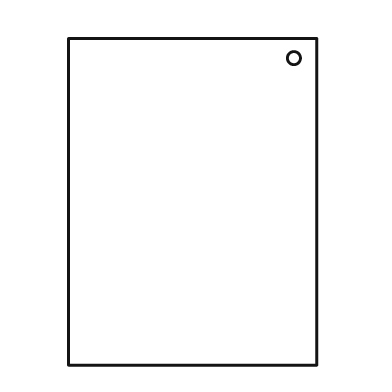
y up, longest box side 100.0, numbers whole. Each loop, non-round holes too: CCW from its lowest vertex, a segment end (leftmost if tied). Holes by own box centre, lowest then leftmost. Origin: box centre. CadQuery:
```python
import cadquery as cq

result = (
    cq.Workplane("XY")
    .moveTo(-38.0, -50.0)
    .lineTo(38.0, -50.0)
    .lineTo(38.0, 50.0)
    .lineTo(-38.0, 50.0)
    .close()
    .moveTo(31.0, 44.0)
    .circle(2.0)
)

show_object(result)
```